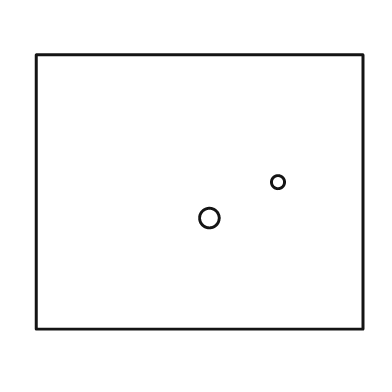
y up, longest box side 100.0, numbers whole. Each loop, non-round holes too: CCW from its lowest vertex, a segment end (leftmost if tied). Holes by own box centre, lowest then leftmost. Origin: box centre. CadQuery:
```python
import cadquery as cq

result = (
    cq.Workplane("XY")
    .moveTo(-50.0, -42.0)
    .lineTo(50.0, -42.0)
    .lineTo(50.0, 42.0)
    .lineTo(-50.0, 42.0)
    .close()
    .moveTo(3.0, -8.0)
    .circle(3.0)
    .moveTo(24.0, 3.0)
    .circle(2.0)
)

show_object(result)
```